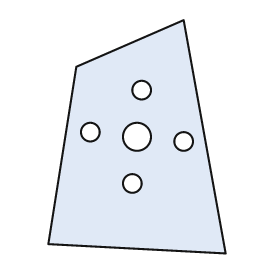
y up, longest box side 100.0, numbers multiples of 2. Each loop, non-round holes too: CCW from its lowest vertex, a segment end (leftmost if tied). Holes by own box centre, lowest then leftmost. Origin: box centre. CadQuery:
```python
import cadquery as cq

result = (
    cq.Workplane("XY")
    .moveTo(38.0, -50.0)
    .lineTo(20.0, 50.0)
    .lineTo(-26.0, 30.0)
    .lineTo(-38.0, -46.0)
    .close()
    .moveTo(-2.0, -20.0)
    .circle(4.0)
    .moveTo(20.0, -2.0)
    .circle(4.0)
    .moveTo(0.0, 0.0)
    .circle(6.0)
    .moveTo(-20.0, 2.0)
    .circle(4.0)
    .moveTo(2.0, 20.0)
    .circle(4.0)
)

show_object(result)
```